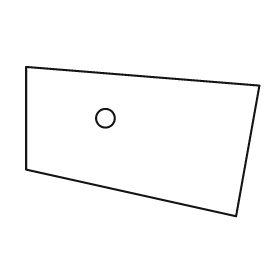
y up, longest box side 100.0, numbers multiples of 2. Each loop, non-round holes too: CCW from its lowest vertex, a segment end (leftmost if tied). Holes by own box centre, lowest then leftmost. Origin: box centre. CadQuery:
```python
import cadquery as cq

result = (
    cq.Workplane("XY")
    .moveTo(40.0, -32.0)
    .lineTo(50.0, 24.0)
    .lineTo(-50.0, 32.0)
    .lineTo(-50.0, -12.0)
    .close()
    .moveTo(-16.0, 10.0)
    .circle(4.0)
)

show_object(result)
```